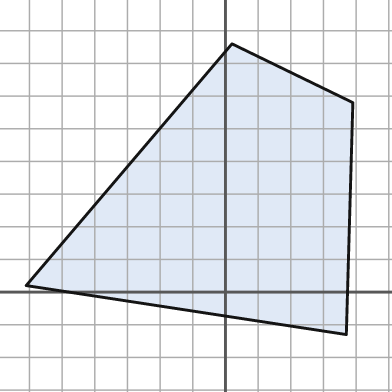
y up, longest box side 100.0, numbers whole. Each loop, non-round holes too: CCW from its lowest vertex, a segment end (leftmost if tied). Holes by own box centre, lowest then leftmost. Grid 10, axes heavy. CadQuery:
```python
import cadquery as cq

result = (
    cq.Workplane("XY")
    .moveTo(37.0, -13.0)
    .lineTo(39.0, 58.0)
    .lineTo(2.0, 76.0)
    .lineTo(-61.0, 2.0)
    .close()
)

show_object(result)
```